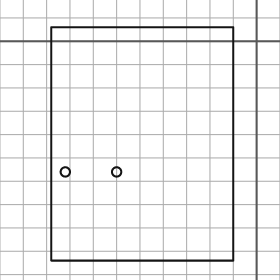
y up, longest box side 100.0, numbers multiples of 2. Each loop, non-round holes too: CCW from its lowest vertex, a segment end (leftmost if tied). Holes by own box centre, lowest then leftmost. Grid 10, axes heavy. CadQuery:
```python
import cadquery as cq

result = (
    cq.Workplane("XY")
    .moveTo(-88.0, -94.0)
    .lineTo(-10.0, -94.0)
    .lineTo(-10.0, 6.0)
    .lineTo(-88.0, 6.0)
    .close()
    .moveTo(-82.0, -56.0)
    .circle(2.0)
    .moveTo(-60.0, -56.0)
    .circle(2.0)
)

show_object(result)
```